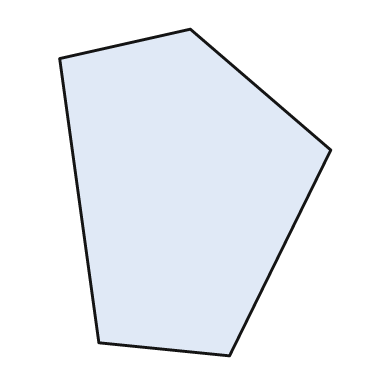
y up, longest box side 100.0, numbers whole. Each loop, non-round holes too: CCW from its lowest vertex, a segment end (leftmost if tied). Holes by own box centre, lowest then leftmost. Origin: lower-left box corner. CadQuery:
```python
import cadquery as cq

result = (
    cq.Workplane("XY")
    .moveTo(52.0, 0.0)
    .lineTo(83.0, 63.0)
    .lineTo(40.0, 100.0)
    .lineTo(0.0, 91.0)
    .lineTo(12.0, 4.0)
    .close()
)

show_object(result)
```